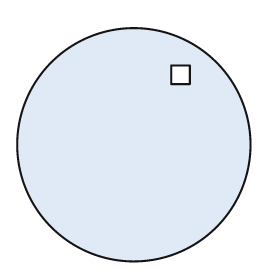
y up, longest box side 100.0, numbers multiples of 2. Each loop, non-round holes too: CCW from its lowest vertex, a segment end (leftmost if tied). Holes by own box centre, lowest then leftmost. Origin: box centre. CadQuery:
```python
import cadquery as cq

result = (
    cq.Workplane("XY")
    .moveTo(0.0, 0.0)
    .circle(50.0)
    .moveTo(16.0, 26.0)
    .lineTo(24.0, 26.0)
    .lineTo(24.0, 34.0)
    .lineTo(16.0, 34.0)
    .close()
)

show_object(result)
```